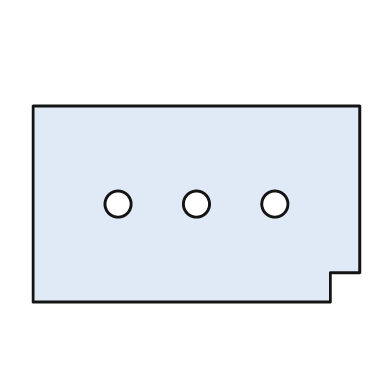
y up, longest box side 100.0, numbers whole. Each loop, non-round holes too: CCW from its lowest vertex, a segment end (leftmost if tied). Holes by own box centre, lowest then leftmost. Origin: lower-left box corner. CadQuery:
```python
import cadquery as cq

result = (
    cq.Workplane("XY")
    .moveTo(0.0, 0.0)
    .lineTo(91.0, 0.0)
    .lineTo(91.0, 9.0)
    .lineTo(100.0, 9.0)
    .lineTo(100.0, 60.0)
    .lineTo(0.0, 60.0)
    .close()
    .moveTo(26.0, 30.0)
    .circle(4.0)
    .moveTo(50.0, 30.0)
    .circle(4.0)
    .moveTo(74.0, 30.0)
    .circle(4.0)
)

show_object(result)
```